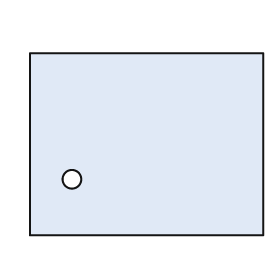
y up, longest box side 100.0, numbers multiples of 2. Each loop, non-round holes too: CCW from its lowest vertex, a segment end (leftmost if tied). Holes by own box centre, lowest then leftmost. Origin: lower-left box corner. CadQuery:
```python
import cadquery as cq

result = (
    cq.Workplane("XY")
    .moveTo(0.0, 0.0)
    .lineTo(100.0, 0.0)
    .lineTo(100.0, 78.0)
    .lineTo(0.0, 78.0)
    .close()
    .moveTo(18.0, 24.0)
    .circle(4.0)
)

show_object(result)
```